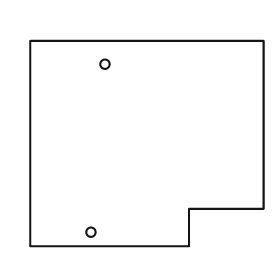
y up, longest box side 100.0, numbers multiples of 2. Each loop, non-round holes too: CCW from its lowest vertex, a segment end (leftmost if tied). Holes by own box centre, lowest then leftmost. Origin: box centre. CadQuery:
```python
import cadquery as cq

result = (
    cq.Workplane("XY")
    .moveTo(-50.0, -44.0)
    .lineTo(18.0, -44.0)
    .lineTo(18.0, -28.0)
    .lineTo(50.0, -28.0)
    .lineTo(50.0, 44.0)
    .lineTo(-50.0, 44.0)
    .close()
    .moveTo(-24.0, -38.0)
    .circle(2.0)
    .moveTo(-18.0, 34.0)
    .circle(2.0)
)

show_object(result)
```